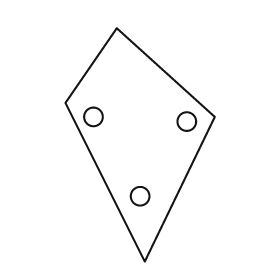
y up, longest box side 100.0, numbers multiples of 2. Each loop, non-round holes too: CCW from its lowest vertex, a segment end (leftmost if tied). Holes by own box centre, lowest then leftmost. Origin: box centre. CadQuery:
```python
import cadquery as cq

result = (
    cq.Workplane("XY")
    .moveTo(2.0, -50.0)
    .lineTo(32.0, 12.0)
    .lineTo(-10.0, 50.0)
    .lineTo(-32.0, 18.0)
    .close()
    .moveTo(0.0, -22.0)
    .circle(4.0)
    .moveTo(20.0, 10.0)
    .circle(4.0)
    .moveTo(-20.0, 12.0)
    .circle(4.0)
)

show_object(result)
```